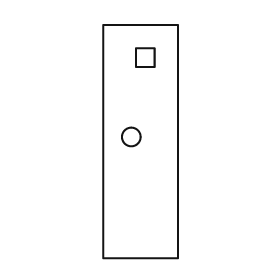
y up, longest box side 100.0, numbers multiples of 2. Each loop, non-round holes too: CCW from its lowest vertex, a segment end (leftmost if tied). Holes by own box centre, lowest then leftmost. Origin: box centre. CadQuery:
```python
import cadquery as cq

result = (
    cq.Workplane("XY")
    .moveTo(-16.0, -50.0)
    .lineTo(16.0, -50.0)
    .lineTo(16.0, 50.0)
    .lineTo(-16.0, 50.0)
    .close()
    .moveTo(-4.0, 2.0)
    .circle(4.0)
    .moveTo(-2.0, 32.0)
    .lineTo(6.0, 32.0)
    .lineTo(6.0, 40.0)
    .lineTo(-2.0, 40.0)
    .close()
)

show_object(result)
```